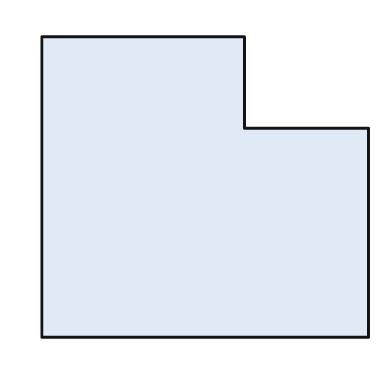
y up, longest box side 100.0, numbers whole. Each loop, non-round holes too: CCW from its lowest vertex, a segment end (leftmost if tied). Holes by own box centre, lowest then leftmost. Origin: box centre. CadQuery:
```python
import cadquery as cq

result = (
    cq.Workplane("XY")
    .moveTo(-50.0, -46.0)
    .lineTo(50.0, -46.0)
    .lineTo(50.0, 18.0)
    .lineTo(12.0, 18.0)
    .lineTo(12.0, 46.0)
    .lineTo(-50.0, 46.0)
    .close()
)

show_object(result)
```